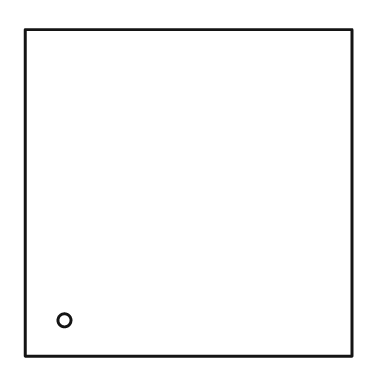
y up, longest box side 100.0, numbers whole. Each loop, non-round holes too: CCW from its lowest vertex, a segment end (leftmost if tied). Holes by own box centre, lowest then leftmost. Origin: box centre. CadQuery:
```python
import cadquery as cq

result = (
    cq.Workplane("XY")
    .moveTo(-50.0, -50.0)
    .lineTo(50.0, -50.0)
    .lineTo(50.0, 50.0)
    .lineTo(-50.0, 50.0)
    .close()
    .moveTo(-38.0, -39.0)
    .circle(2.0)
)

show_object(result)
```